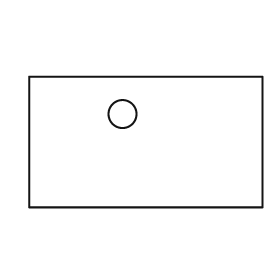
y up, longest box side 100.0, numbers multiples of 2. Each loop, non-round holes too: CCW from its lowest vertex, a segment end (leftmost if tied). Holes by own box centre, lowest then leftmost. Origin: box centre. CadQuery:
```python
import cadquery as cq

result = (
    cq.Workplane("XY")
    .moveTo(-50.0, -28.0)
    .lineTo(50.0, -28.0)
    .lineTo(50.0, 28.0)
    .lineTo(-50.0, 28.0)
    .close()
    .moveTo(-10.0, 12.0)
    .circle(6.0)
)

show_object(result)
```